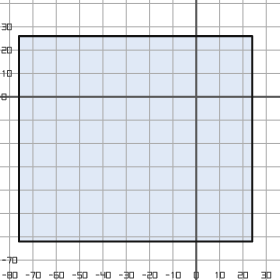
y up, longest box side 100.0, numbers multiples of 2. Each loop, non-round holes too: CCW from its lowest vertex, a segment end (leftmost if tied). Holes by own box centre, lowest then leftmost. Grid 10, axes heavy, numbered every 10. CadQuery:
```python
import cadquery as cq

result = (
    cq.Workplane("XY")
    .moveTo(-76.0, -62.0)
    .lineTo(24.0, -62.0)
    .lineTo(24.0, 26.0)
    .lineTo(-76.0, 26.0)
    .close()
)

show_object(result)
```